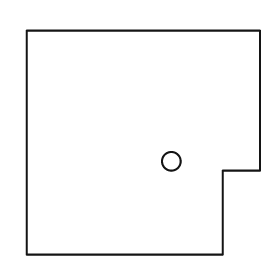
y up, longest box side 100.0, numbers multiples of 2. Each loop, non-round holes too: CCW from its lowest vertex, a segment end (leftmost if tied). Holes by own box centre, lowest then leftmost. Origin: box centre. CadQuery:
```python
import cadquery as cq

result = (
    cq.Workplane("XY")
    .moveTo(-50.0, -48.0)
    .lineTo(34.0, -48.0)
    .lineTo(34.0, -12.0)
    .lineTo(50.0, -12.0)
    .lineTo(50.0, 48.0)
    .lineTo(-50.0, 48.0)
    .close()
    .moveTo(12.0, -8.0)
    .circle(4.0)
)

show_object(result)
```